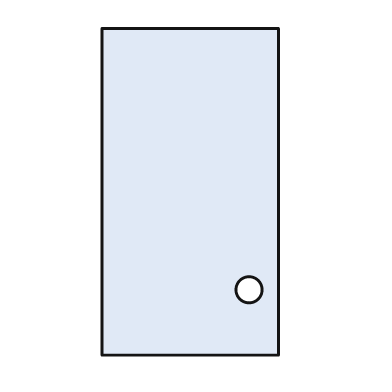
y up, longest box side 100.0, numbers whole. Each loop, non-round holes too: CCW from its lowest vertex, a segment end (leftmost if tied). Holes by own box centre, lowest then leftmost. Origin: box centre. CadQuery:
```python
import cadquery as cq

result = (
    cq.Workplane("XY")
    .moveTo(-27.0, -50.0)
    .lineTo(27.0, -50.0)
    .lineTo(27.0, 50.0)
    .lineTo(-27.0, 50.0)
    .close()
    .moveTo(18.0, -30.0)
    .circle(4.0)
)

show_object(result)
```